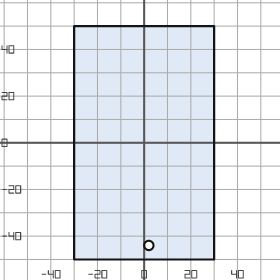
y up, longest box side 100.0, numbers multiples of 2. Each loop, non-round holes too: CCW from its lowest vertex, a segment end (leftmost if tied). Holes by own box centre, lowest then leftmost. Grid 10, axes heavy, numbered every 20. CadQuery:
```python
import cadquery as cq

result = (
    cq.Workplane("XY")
    .moveTo(-30.0, -50.0)
    .lineTo(30.0, -50.0)
    .lineTo(30.0, 50.0)
    .lineTo(-30.0, 50.0)
    .close()
    .moveTo(2.0, -44.0)
    .circle(2.0)
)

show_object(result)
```